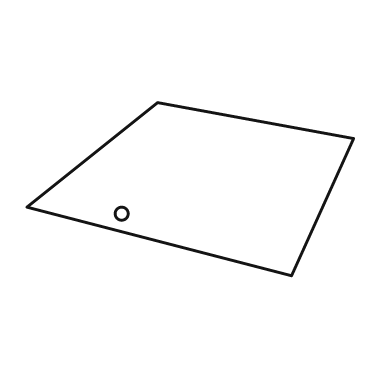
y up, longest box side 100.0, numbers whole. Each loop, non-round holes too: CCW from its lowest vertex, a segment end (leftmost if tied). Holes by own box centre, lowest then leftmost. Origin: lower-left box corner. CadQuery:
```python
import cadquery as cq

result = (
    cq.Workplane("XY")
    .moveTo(81.0, 0.0)
    .lineTo(100.0, 42.0)
    .lineTo(40.0, 53.0)
    .lineTo(0.0, 21.0)
    .close()
    .moveTo(29.0, 19.0)
    .circle(2.0)
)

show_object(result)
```